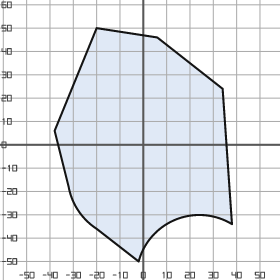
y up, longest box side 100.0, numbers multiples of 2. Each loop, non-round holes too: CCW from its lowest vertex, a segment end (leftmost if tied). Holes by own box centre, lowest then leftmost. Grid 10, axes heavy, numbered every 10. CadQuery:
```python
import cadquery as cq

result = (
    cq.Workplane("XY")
    .moveTo(-2.0, -50.0)
    .threePointArc((14.0, -32.0), (38.0, -34.0))
    .lineTo(34.0, 24.0)
    .lineTo(6.0, 46.0)
    .lineTo(-20.0, 50.0)
    .lineTo(-38.0, 6.0)
    .lineTo(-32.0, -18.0)
    .threePointArc((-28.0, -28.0), (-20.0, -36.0))
    .close()
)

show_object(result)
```